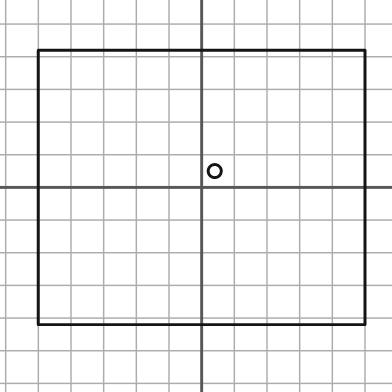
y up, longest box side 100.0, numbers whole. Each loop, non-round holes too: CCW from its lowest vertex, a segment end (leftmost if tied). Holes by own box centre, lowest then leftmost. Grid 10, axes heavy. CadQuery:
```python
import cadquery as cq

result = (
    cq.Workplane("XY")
    .moveTo(-50.0, -42.0)
    .lineTo(50.0, -42.0)
    .lineTo(50.0, 42.0)
    .lineTo(-50.0, 42.0)
    .close()
    .moveTo(4.0, 5.0)
    .circle(2.0)
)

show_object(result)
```